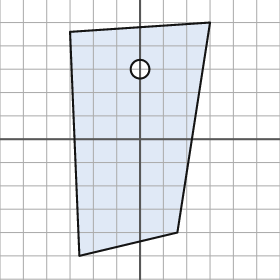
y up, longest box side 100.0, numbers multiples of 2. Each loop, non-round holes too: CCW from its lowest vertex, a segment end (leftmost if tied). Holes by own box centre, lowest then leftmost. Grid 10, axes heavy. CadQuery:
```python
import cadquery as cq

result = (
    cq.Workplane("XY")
    .moveTo(-26.0, -50.0)
    .lineTo(16.0, -40.0)
    .lineTo(30.0, 50.0)
    .lineTo(-30.0, 46.0)
    .close()
    .moveTo(0.0, 30.0)
    .circle(4.0)
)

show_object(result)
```